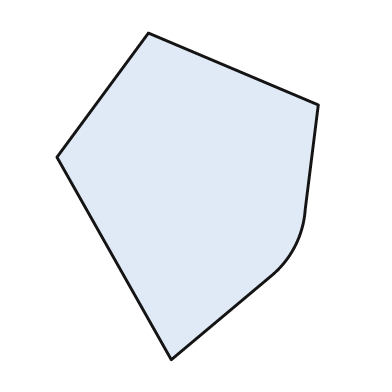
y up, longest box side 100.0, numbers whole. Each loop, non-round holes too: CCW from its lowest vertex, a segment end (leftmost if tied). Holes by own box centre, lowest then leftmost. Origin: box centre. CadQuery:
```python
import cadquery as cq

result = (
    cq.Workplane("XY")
    .moveTo(-5.0, -50.0)
    .lineTo(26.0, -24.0)
    .threePointArc((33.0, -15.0), (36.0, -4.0))
    .lineTo(40.0, 28.0)
    .lineTo(-12.0, 50.0)
    .lineTo(-40.0, 12.0)
    .close()
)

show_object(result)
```